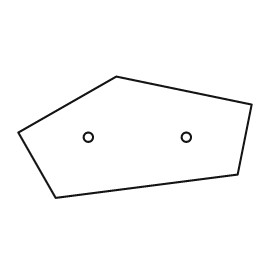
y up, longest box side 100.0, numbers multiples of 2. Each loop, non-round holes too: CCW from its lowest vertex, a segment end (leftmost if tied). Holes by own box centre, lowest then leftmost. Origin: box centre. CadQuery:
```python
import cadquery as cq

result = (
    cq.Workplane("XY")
    .moveTo(-34.0, -26.0)
    .lineTo(44.0, -16.0)
    .lineTo(50.0, 14.0)
    .lineTo(-8.0, 26.0)
    .lineTo(-50.0, 2.0)
    .close()
    .moveTo(-20.0, 0.0)
    .circle(2.0)
    .moveTo(22.0, 0.0)
    .circle(2.0)
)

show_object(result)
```